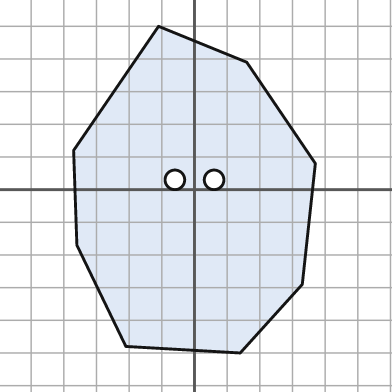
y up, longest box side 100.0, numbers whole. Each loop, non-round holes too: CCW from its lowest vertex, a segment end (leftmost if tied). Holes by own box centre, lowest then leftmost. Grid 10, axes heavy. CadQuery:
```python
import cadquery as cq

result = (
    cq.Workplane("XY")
    .moveTo(14.0, -50.0)
    .lineTo(33.0, -29.0)
    .lineTo(37.0, 8.0)
    .lineTo(16.0, 39.0)
    .lineTo(-11.0, 50.0)
    .lineTo(-37.0, 12.0)
    .lineTo(-36.0, -17.0)
    .lineTo(-21.0, -48.0)
    .close()
    .moveTo(-6.0, 3.0)
    .circle(3.0)
    .moveTo(6.0, 3.0)
    .circle(3.0)
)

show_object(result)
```